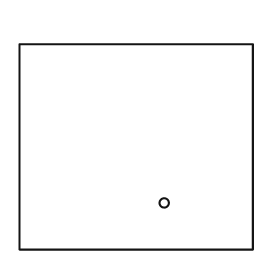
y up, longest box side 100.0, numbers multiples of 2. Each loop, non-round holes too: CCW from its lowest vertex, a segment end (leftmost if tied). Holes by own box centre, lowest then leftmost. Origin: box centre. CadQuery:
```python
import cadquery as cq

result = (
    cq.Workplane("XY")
    .moveTo(-50.0, -44.0)
    .lineTo(50.0, -44.0)
    .lineTo(50.0, 44.0)
    .lineTo(-50.0, 44.0)
    .close()
    .moveTo(12.0, -24.0)
    .circle(2.0)
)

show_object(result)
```